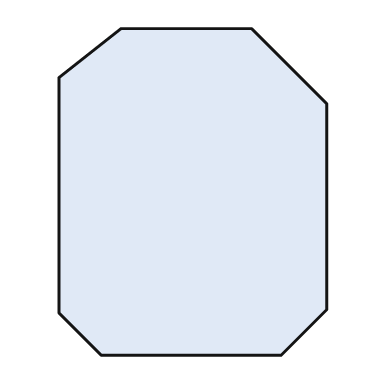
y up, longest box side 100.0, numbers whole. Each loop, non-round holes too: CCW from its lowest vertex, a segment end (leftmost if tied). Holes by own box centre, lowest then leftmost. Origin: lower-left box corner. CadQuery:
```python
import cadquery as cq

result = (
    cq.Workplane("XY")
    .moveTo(13.0, 0.0)
    .lineTo(68.0, 0.0)
    .lineTo(82.0, 14.0)
    .lineTo(82.0, 77.0)
    .lineTo(59.0, 100.0)
    .lineTo(19.0, 100.0)
    .lineTo(0.0, 85.0)
    .lineTo(0.0, 13.0)
    .close()
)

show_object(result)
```